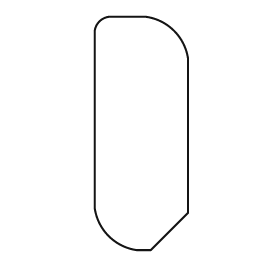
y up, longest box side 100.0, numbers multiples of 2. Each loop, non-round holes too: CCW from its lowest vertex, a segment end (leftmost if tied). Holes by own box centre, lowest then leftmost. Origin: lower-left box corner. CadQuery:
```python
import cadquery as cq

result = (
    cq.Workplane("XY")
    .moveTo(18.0, 0.0)
    .lineTo(24.0, 0.0)
    .lineTo(40.0, 16.0)
    .lineTo(40.0, 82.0)
    .threePointArc((34.0, 94.0), (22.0, 100.0))
    .lineTo(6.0, 100.0)
    .threePointArc((2.0, 98.0), (0.0, 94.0))
    .lineTo(0.0, 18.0)
    .threePointArc((6.0, 6.0), (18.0, 0.0))
    .close()
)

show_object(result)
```